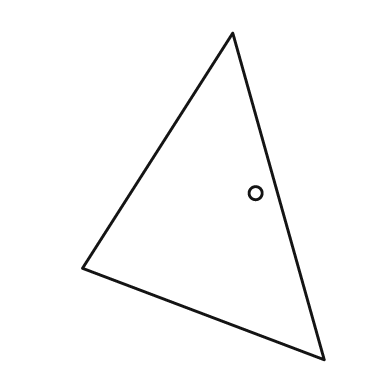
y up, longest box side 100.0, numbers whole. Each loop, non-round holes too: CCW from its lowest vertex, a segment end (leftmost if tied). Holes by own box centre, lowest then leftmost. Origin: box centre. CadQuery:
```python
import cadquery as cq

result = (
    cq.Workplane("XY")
    .moveTo(37.0, -50.0)
    .lineTo(9.0, 50.0)
    .lineTo(-37.0, -22.0)
    .close()
    .moveTo(16.0, 1.0)
    .circle(2.0)
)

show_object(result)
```